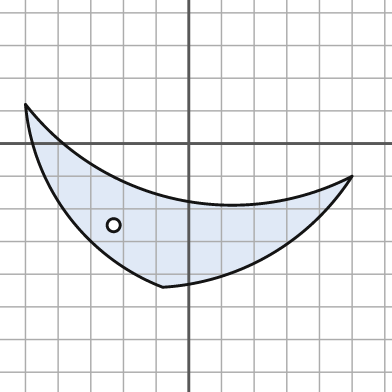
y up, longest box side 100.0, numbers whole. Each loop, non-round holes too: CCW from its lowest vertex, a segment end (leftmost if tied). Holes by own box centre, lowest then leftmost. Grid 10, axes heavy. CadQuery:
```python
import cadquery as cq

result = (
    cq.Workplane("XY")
    .moveTo(-8.0, -44.0)
    .threePointArc((25.0, -34.0), (50.0, -10.0))
    .threePointArc((-4.0, -17.0), (-50.0, 12.0))
    .threePointArc((-37.0, -22.0), (-8.0, -44.0))
    .close()
    .moveTo(-23.0, -25.0)
    .circle(2.0)
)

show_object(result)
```